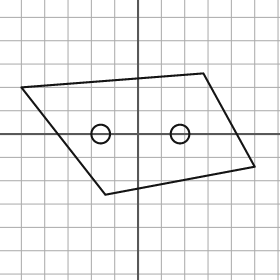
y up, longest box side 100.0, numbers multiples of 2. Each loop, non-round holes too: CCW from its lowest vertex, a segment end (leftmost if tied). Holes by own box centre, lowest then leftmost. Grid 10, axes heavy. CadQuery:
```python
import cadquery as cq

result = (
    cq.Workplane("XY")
    .moveTo(-14.0, -26.0)
    .lineTo(50.0, -14.0)
    .lineTo(28.0, 26.0)
    .lineTo(-50.0, 20.0)
    .close()
    .moveTo(-16.0, 0.0)
    .circle(4.0)
    .moveTo(18.0, 0.0)
    .circle(4.0)
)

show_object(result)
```